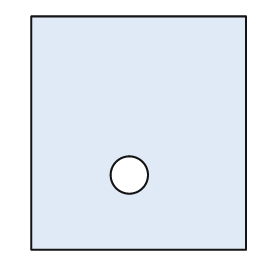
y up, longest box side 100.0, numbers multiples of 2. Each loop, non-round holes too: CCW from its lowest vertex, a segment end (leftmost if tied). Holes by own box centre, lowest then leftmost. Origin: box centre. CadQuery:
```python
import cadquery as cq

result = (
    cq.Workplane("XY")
    .moveTo(-46.0, -50.0)
    .lineTo(46.0, -50.0)
    .lineTo(46.0, 50.0)
    .lineTo(-46.0, 50.0)
    .close()
    .moveTo(-4.0, -18.0)
    .circle(8.0)
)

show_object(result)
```